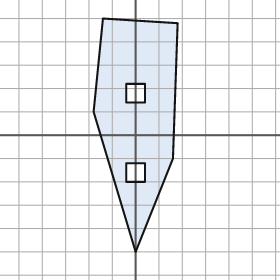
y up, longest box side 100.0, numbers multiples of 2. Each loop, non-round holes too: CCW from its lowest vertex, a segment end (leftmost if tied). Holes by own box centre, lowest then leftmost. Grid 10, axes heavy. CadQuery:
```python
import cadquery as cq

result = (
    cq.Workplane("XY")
    .moveTo(0.0, -50.0)
    .lineTo(16.0, -10.0)
    .lineTo(18.0, 48.0)
    .lineTo(-14.0, 50.0)
    .lineTo(-18.0, 10.0)
    .close()
    .moveTo(-4.0, -20.0)
    .lineTo(4.0, -20.0)
    .lineTo(4.0, -12.0)
    .lineTo(-4.0, -12.0)
    .close()
    .moveTo(-4.0, 14.0)
    .lineTo(4.0, 14.0)
    .lineTo(4.0, 22.0)
    .lineTo(-4.0, 22.0)
    .close()
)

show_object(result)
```